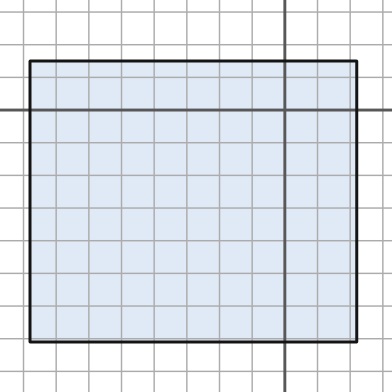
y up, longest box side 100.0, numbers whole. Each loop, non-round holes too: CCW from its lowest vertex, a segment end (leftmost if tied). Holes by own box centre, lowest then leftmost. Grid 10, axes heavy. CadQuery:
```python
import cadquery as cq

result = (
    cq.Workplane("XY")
    .moveTo(-78.0, -71.0)
    .lineTo(22.0, -71.0)
    .lineTo(22.0, 15.0)
    .lineTo(-78.0, 15.0)
    .close()
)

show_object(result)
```